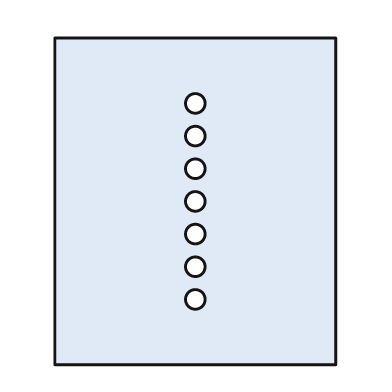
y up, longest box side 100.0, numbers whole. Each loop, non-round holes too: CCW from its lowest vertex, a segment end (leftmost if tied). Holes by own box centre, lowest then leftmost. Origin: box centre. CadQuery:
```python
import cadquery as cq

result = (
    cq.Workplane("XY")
    .moveTo(-43.0, -50.0)
    .lineTo(43.0, -50.0)
    .lineTo(43.0, 50.0)
    .lineTo(-43.0, 50.0)
    .close()
    .moveTo(0.0, -30.0)
    .circle(3.0)
    .moveTo(0.0, -20.0)
    .circle(3.0)
    .moveTo(0.0, -10.0)
    .circle(3.0)
    .moveTo(0.0, 0.0)
    .circle(3.0)
    .moveTo(0.0, 10.0)
    .circle(3.0)
    .moveTo(0.0, 20.0)
    .circle(3.0)
    .moveTo(0.0, 30.0)
    .circle(3.0)
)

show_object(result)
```